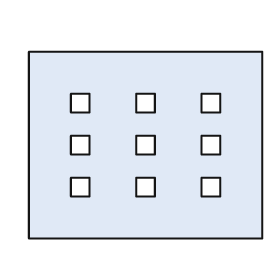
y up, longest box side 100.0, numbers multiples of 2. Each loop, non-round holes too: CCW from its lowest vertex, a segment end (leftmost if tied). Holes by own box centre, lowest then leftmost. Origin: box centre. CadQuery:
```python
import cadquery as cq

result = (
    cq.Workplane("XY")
    .moveTo(-50.0, -40.0)
    .lineTo(50.0, -40.0)
    .lineTo(50.0, 40.0)
    .lineTo(-50.0, 40.0)
    .close()
    .moveTo(-32.0, -22.0)
    .lineTo(-24.0, -22.0)
    .lineTo(-24.0, -14.0)
    .lineTo(-32.0, -14.0)
    .close()
    .moveTo(-4.0, -22.0)
    .lineTo(4.0, -22.0)
    .lineTo(4.0, -14.0)
    .lineTo(-4.0, -14.0)
    .close()
    .moveTo(24.0, -22.0)
    .lineTo(32.0, -22.0)
    .lineTo(32.0, -14.0)
    .lineTo(24.0, -14.0)
    .close()
    .moveTo(-32.0, -4.0)
    .lineTo(-24.0, -4.0)
    .lineTo(-24.0, 4.0)
    .lineTo(-32.0, 4.0)
    .close()
    .moveTo(-4.0, -4.0)
    .lineTo(4.0, -4.0)
    .lineTo(4.0, 4.0)
    .lineTo(-4.0, 4.0)
    .close()
    .moveTo(24.0, -4.0)
    .lineTo(32.0, -4.0)
    .lineTo(32.0, 4.0)
    .lineTo(24.0, 4.0)
    .close()
    .moveTo(-32.0, 14.0)
    .lineTo(-24.0, 14.0)
    .lineTo(-24.0, 22.0)
    .lineTo(-32.0, 22.0)
    .close()
    .moveTo(-4.0, 14.0)
    .lineTo(4.0, 14.0)
    .lineTo(4.0, 22.0)
    .lineTo(-4.0, 22.0)
    .close()
    .moveTo(24.0, 14.0)
    .lineTo(32.0, 14.0)
    .lineTo(32.0, 22.0)
    .lineTo(24.0, 22.0)
    .close()
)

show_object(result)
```